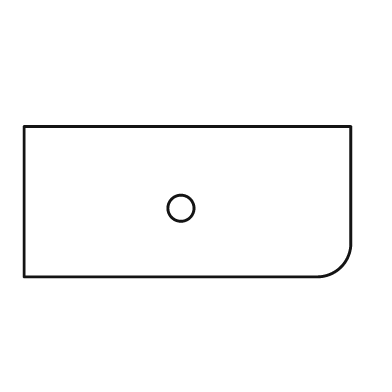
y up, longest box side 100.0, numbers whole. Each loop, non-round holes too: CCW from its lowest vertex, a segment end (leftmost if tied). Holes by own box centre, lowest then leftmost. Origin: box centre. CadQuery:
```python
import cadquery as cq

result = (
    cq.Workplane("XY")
    .moveTo(-50.0, -23.0)
    .lineTo(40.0, -23.0)
    .threePointArc((47.0, -20.0), (50.0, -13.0))
    .lineTo(50.0, 23.0)
    .lineTo(-50.0, 23.0)
    .close()
    .moveTo(-2.0, -2.0)
    .circle(4.0)
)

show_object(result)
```